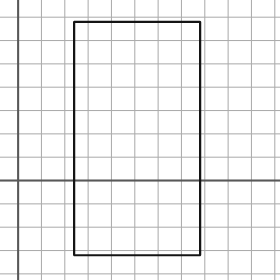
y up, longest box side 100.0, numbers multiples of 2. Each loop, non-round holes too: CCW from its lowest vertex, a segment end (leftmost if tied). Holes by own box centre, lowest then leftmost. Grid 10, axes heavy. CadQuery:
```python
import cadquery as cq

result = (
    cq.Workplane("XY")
    .moveTo(24.0, -32.0)
    .lineTo(78.0, -32.0)
    .lineTo(78.0, 68.0)
    .lineTo(24.0, 68.0)
    .close()
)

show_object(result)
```